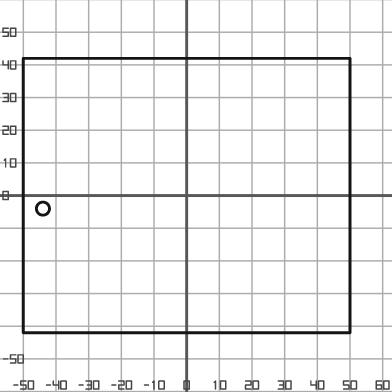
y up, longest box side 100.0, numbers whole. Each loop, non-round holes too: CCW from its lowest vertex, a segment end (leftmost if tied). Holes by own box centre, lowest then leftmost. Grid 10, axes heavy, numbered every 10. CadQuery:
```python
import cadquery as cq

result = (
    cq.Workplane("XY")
    .moveTo(-50.0, -42.0)
    .lineTo(50.0, -42.0)
    .lineTo(50.0, 42.0)
    .lineTo(-50.0, 42.0)
    .close()
    .moveTo(-44.0, -4.0)
    .circle(2.0)
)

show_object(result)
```